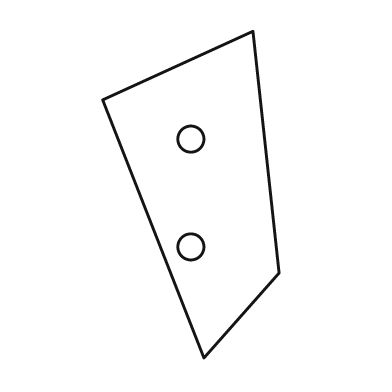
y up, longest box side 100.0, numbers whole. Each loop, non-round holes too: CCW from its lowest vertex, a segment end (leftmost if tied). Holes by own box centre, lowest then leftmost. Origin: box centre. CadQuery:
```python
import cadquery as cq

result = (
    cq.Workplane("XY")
    .moveTo(4.0, -50.0)
    .lineTo(27.0, -24.0)
    .lineTo(19.0, 50.0)
    .lineTo(-27.0, 29.0)
    .close()
    .moveTo(0.0, -16.0)
    .circle(4.0)
    .moveTo(0.0, 17.0)
    .circle(4.0)
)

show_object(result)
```